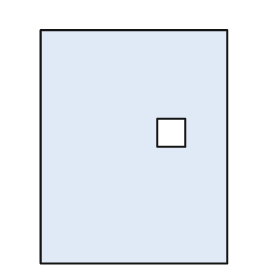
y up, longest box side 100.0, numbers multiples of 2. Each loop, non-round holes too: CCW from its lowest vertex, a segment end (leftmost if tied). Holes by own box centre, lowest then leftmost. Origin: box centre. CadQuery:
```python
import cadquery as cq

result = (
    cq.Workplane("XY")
    .moveTo(-40.0, -50.0)
    .lineTo(40.0, -50.0)
    .lineTo(40.0, 50.0)
    .lineTo(-40.0, 50.0)
    .close()
    .moveTo(10.0, 0.0)
    .lineTo(22.0, 0.0)
    .lineTo(22.0, 12.0)
    .lineTo(10.0, 12.0)
    .close()
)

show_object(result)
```